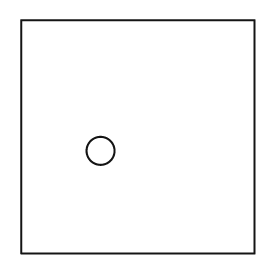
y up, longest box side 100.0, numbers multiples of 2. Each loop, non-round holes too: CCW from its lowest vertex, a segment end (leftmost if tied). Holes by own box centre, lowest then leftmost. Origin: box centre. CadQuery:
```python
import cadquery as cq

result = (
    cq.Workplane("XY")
    .moveTo(-50.0, -50.0)
    .lineTo(50.0, -50.0)
    .lineTo(50.0, 50.0)
    .lineTo(-50.0, 50.0)
    .close()
    .moveTo(-16.0, -6.0)
    .circle(6.0)
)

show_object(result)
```